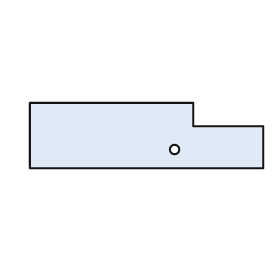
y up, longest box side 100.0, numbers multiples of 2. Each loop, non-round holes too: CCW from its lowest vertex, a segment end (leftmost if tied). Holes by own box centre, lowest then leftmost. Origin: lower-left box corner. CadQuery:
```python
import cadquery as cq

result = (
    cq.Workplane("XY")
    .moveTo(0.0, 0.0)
    .lineTo(100.0, 0.0)
    .lineTo(100.0, 18.0)
    .lineTo(70.0, 18.0)
    .lineTo(70.0, 28.0)
    .lineTo(0.0, 28.0)
    .close()
    .moveTo(62.0, 8.0)
    .circle(2.0)
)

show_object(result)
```